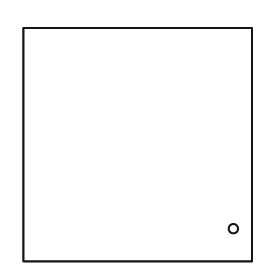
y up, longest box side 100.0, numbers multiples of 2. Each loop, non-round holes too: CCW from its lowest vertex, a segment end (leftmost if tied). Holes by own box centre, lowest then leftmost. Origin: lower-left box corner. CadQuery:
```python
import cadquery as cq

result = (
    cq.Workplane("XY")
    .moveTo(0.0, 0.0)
    .lineTo(98.0, 0.0)
    .lineTo(98.0, 100.0)
    .lineTo(0.0, 100.0)
    .close()
    .moveTo(90.0, 14.0)
    .circle(2.0)
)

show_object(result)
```